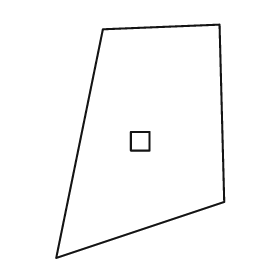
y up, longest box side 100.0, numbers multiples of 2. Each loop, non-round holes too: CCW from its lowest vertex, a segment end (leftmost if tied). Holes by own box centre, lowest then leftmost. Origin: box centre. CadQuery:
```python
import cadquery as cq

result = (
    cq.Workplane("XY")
    .moveTo(-36.0, -50.0)
    .lineTo(36.0, -26.0)
    .lineTo(34.0, 50.0)
    .lineTo(-16.0, 48.0)
    .close()
    .moveTo(-4.0, -4.0)
    .lineTo(4.0, -4.0)
    .lineTo(4.0, 4.0)
    .lineTo(-4.0, 4.0)
    .close()
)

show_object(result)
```